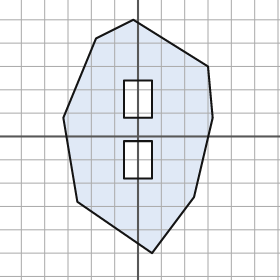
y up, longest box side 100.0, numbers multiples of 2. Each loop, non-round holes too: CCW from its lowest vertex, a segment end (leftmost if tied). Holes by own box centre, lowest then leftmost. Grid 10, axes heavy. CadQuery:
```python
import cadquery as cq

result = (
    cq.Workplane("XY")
    .moveTo(6.0, -50.0)
    .lineTo(24.0, -26.0)
    .lineTo(32.0, 8.0)
    .lineTo(30.0, 30.0)
    .lineTo(-2.0, 50.0)
    .lineTo(-18.0, 42.0)
    .lineTo(-32.0, 8.0)
    .lineTo(-26.0, -28.0)
    .close()
    .moveTo(-6.0, -18.0)
    .lineTo(6.0, -18.0)
    .lineTo(6.0, -2.0)
    .lineTo(-6.0, -2.0)
    .close()
    .moveTo(-6.0, 8.0)
    .lineTo(6.0, 8.0)
    .lineTo(6.0, 24.0)
    .lineTo(-6.0, 24.0)
    .close()
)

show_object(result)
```